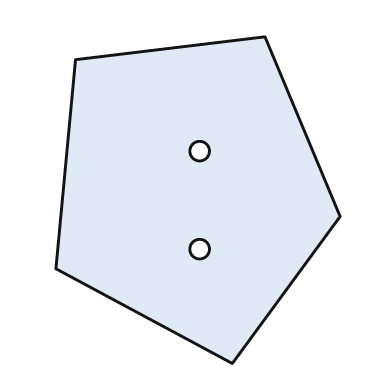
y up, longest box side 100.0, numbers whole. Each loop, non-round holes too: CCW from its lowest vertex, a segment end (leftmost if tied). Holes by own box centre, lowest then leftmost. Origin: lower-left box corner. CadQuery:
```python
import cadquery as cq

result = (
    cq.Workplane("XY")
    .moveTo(54.0, 0.0)
    .lineTo(87.0, 45.0)
    .lineTo(64.0, 100.0)
    .lineTo(6.0, 93.0)
    .lineTo(0.0, 29.0)
    .close()
    .moveTo(44.0, 35.0)
    .circle(3.0)
    .moveTo(44.0, 65.0)
    .circle(3.0)
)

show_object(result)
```